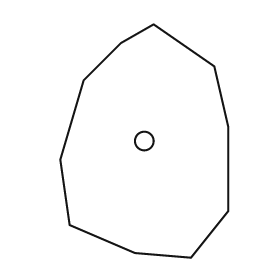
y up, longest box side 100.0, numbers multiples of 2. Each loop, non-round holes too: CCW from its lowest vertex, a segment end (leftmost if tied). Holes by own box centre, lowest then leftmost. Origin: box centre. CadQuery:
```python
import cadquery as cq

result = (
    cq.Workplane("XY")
    .moveTo(20.0, -50.0)
    .lineTo(36.0, -30.0)
    .lineTo(36.0, 6.0)
    .lineTo(30.0, 32.0)
    .lineTo(4.0, 50.0)
    .lineTo(-10.0, 42.0)
    .lineTo(-26.0, 26.0)
    .lineTo(-36.0, -8.0)
    .lineTo(-32.0, -36.0)
    .lineTo(-4.0, -48.0)
    .close()
    .moveTo(0.0, 0.0)
    .circle(4.0)
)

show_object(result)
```